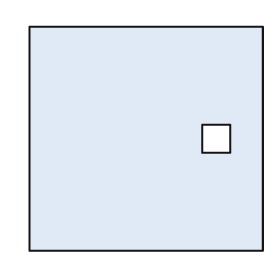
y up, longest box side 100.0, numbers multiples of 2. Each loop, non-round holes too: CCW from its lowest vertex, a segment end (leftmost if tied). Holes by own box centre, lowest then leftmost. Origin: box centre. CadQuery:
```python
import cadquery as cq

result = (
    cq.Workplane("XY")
    .moveTo(-50.0, -48.0)
    .lineTo(50.0, -48.0)
    .lineTo(50.0, 48.0)
    .lineTo(-50.0, 48.0)
    .close()
    .moveTo(24.0, -6.0)
    .lineTo(36.0, -6.0)
    .lineTo(36.0, 6.0)
    .lineTo(24.0, 6.0)
    .close()
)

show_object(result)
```